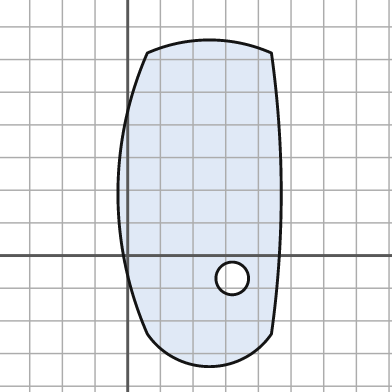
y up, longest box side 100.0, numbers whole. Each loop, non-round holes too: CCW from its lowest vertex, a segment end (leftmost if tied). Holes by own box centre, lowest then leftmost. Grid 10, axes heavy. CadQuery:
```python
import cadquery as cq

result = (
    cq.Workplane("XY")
    .moveTo(6.0, -24.0)
    .threePointArc((25.0, -34.0), (44.0, -24.0))
    .threePointArc((47.0, 19.0), (44.0, 62.0))
    .threePointArc((25.0, 66.0), (6.0, 62.0))
    .threePointArc((-3.0, 19.0), (6.0, -24.0))
    .close()
    .moveTo(32.0, -7.0)
    .circle(5.0)
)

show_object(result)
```